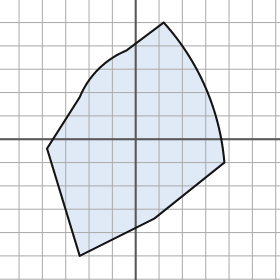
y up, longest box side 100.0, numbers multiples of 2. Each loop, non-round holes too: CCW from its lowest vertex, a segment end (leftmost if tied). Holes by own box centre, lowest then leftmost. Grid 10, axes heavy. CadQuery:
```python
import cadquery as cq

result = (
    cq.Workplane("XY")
    .moveTo(-24.0, -50.0)
    .lineTo(8.0, -34.0)
    .lineTo(38.0, -10.0)
    .threePointArc((30.0, 22.0), (12.0, 50.0))
    .lineTo(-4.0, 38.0)
    .threePointArc((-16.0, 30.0), (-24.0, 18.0))
    .lineTo(-38.0, -4.0)
    .close()
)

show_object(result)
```